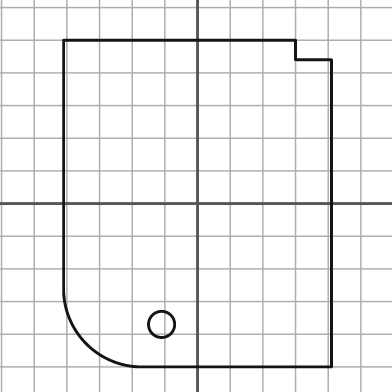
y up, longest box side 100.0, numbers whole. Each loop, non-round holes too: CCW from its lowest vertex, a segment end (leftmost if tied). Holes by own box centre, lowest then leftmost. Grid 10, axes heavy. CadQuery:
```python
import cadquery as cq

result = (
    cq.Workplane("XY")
    .moveTo(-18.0, -50.0)
    .lineTo(41.0, -50.0)
    .lineTo(41.0, 44.0)
    .lineTo(30.0, 44.0)
    .lineTo(30.0, 50.0)
    .lineTo(-41.0, 50.0)
    .lineTo(-41.0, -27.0)
    .threePointArc((-34.0, -43.0), (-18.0, -50.0))
    .close()
    .moveTo(-11.0, -37.0)
    .circle(4.0)
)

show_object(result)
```